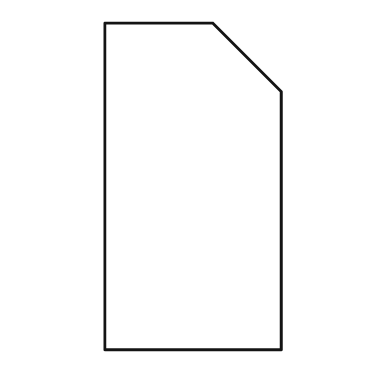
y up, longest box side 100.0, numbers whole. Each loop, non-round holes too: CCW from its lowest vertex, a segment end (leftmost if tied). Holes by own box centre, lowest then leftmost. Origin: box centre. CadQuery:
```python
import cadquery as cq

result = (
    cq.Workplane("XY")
    .moveTo(-27.0, -50.0)
    .lineTo(27.0, -50.0)
    .lineTo(27.0, 29.0)
    .lineTo(6.0, 50.0)
    .lineTo(-27.0, 50.0)
    .close()
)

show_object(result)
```